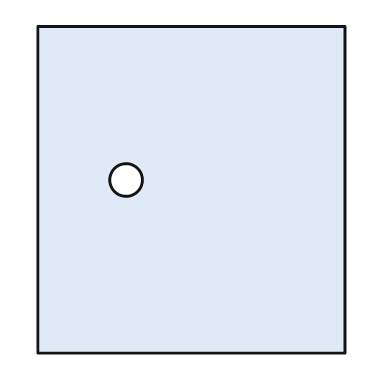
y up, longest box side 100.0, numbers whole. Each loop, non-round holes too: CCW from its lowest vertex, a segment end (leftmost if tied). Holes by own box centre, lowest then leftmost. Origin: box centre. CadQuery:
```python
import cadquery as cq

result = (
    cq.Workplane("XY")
    .moveTo(-47.0, -50.0)
    .lineTo(47.0, -50.0)
    .lineTo(47.0, 50.0)
    .lineTo(-47.0, 50.0)
    .close()
    .moveTo(-20.0, 3.0)
    .circle(5.0)
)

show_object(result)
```